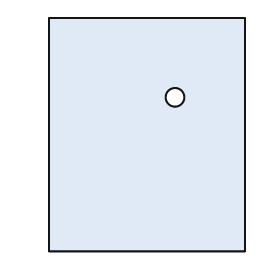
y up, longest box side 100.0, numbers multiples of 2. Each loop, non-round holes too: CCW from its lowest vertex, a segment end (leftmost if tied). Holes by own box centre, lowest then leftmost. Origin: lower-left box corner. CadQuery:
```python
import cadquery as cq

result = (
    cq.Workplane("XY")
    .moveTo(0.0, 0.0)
    .lineTo(84.0, 0.0)
    .lineTo(84.0, 100.0)
    .lineTo(0.0, 100.0)
    .close()
    .moveTo(54.0, 66.0)
    .circle(4.0)
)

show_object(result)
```